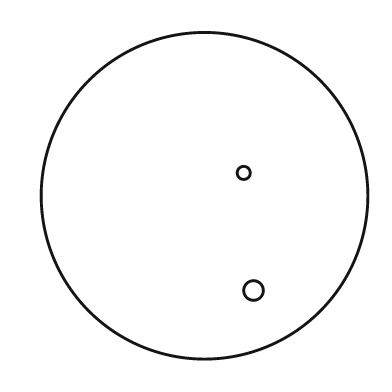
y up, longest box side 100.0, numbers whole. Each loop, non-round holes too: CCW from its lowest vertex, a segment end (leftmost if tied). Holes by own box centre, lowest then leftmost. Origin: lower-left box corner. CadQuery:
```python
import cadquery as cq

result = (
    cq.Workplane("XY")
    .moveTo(50.0, 50.0)
    .circle(50.0)
    .moveTo(65.0, 21.0)
    .circle(3.0)
    .moveTo(62.0, 57.0)
    .circle(2.0)
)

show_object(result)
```